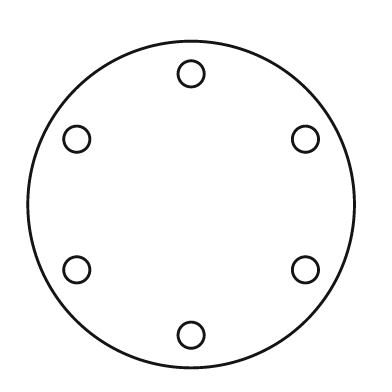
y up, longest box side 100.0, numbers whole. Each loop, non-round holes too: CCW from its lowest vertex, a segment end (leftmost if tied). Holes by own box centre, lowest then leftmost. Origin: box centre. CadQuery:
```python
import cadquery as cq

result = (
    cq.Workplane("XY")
    .moveTo(0.0, 0.0)
    .circle(50.0)
    .moveTo(0.0, -40.0)
    .circle(4.0)
    .moveTo(-35.0, -20.0)
    .circle(4.0)
    .moveTo(35.0, -20.0)
    .circle(4.0)
    .moveTo(-35.0, 20.0)
    .circle(4.0)
    .moveTo(35.0, 20.0)
    .circle(4.0)
    .moveTo(0.0, 40.0)
    .circle(4.0)
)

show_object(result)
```